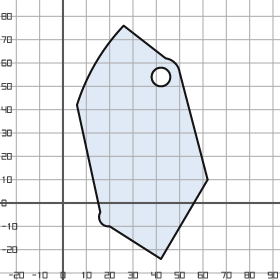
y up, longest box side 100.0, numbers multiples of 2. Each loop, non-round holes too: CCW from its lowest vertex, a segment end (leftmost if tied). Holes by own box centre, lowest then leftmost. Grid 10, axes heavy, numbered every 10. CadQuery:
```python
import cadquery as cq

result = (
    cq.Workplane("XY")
    .moveTo(42.0, -24.0)
    .lineTo(62.0, 10.0)
    .lineTo(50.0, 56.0)
    .threePointArc((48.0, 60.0), (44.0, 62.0))
    .lineTo(26.0, 76.0)
    .threePointArc((14.0, 60.0), (6.0, 42.0))
    .lineTo(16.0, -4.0)
    .threePointArc((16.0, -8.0), (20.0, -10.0))
    .close()
    .moveTo(42.0, 54.0)
    .circle(4.0)
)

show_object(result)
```